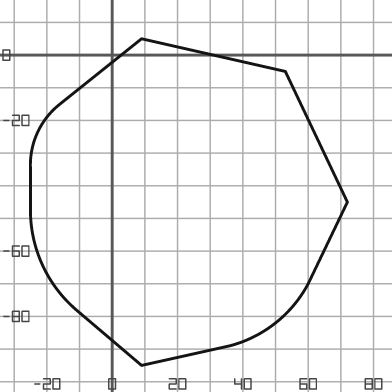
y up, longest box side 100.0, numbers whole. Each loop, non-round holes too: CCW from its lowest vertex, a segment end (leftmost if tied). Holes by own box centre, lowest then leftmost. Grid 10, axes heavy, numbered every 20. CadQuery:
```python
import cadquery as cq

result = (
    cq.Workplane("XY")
    .moveTo(9.0, -95.0)
    .lineTo(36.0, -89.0)
    .threePointArc((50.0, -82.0), (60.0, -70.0))
    .lineTo(72.0, -45.0)
    .lineTo(53.0, -5.0)
    .lineTo(9.0, 5.0)
    .lineTo(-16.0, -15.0)
    .threePointArc((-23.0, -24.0), (-25.0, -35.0))
    .lineTo(-25.0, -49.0)
    .threePointArc((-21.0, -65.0), (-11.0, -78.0))
    .close()
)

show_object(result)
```